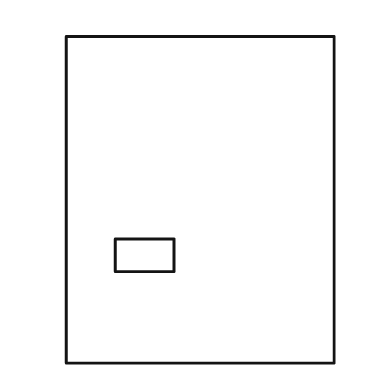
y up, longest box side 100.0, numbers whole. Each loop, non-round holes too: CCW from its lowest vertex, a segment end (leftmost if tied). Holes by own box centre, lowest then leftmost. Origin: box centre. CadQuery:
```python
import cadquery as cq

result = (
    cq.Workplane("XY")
    .moveTo(-41.0, -50.0)
    .lineTo(41.0, -50.0)
    .lineTo(41.0, 50.0)
    .lineTo(-41.0, 50.0)
    .close()
    .moveTo(-26.0, -22.0)
    .lineTo(-8.0, -22.0)
    .lineTo(-8.0, -12.0)
    .lineTo(-26.0, -12.0)
    .close()
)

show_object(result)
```